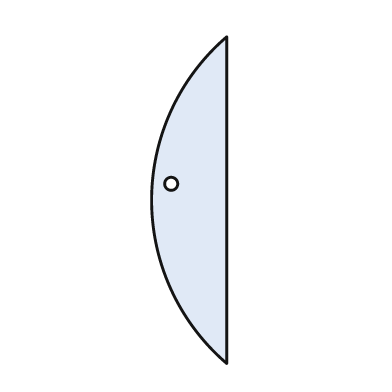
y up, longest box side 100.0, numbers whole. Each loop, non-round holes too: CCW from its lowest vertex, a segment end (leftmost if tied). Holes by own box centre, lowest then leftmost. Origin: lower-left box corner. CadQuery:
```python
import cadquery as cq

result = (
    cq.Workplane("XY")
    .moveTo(23.0, 0.0)
    .lineTo(23.0, 100.0)
    .threePointArc((0.0, 50.0), (23.0, 0.0))
    .close()
    .moveTo(6.0, 55.0)
    .circle(2.0)
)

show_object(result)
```